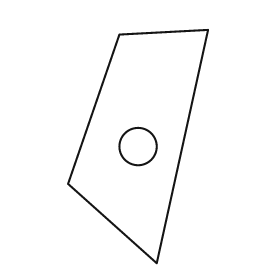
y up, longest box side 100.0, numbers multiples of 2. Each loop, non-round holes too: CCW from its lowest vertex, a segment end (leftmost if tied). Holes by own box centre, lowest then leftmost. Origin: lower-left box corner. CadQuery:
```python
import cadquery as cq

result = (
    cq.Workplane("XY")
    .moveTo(38.0, 0.0)
    .lineTo(60.0, 100.0)
    .lineTo(22.0, 98.0)
    .lineTo(0.0, 34.0)
    .close()
    .moveTo(30.0, 50.0)
    .circle(8.0)
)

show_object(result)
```